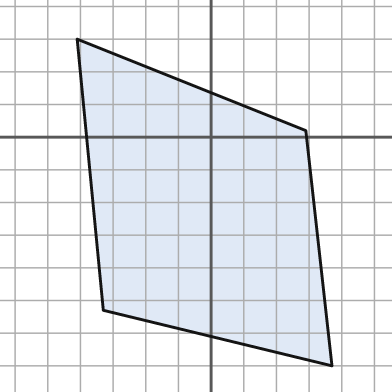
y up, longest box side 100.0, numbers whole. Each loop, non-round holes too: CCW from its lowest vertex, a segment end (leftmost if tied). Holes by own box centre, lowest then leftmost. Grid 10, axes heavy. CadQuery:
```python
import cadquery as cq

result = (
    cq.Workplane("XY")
    .moveTo(37.0, -70.0)
    .lineTo(29.0, 2.0)
    .lineTo(-41.0, 30.0)
    .lineTo(-33.0, -53.0)
    .close()
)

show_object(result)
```